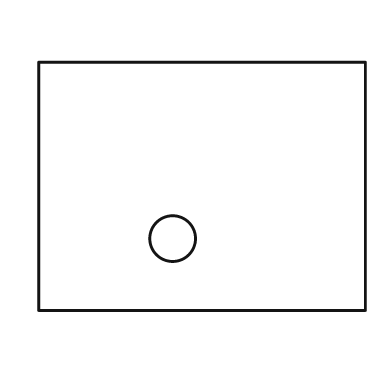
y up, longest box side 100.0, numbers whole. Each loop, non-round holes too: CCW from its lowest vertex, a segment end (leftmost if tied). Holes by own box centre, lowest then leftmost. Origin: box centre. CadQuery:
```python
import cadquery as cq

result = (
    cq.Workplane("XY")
    .moveTo(-50.0, -38.0)
    .lineTo(50.0, -38.0)
    .lineTo(50.0, 38.0)
    .lineTo(-50.0, 38.0)
    .close()
    .moveTo(-9.0, -16.0)
    .circle(7.0)
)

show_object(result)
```